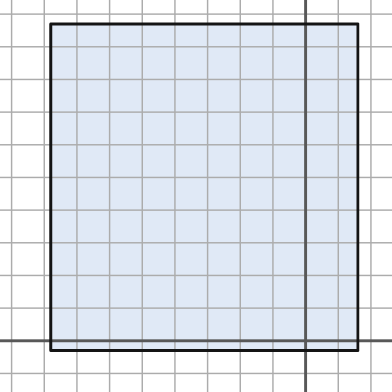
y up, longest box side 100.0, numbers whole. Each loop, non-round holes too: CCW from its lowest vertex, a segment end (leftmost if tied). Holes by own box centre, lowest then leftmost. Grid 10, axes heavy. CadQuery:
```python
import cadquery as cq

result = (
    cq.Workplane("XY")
    .moveTo(-78.0, -3.0)
    .lineTo(16.0, -3.0)
    .lineTo(16.0, 97.0)
    .lineTo(-78.0, 97.0)
    .close()
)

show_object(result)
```